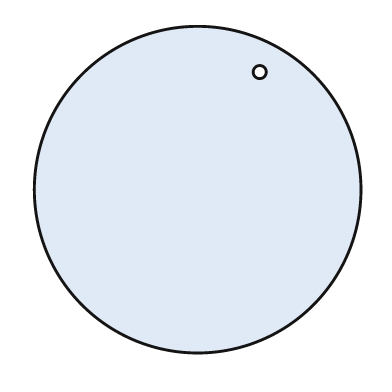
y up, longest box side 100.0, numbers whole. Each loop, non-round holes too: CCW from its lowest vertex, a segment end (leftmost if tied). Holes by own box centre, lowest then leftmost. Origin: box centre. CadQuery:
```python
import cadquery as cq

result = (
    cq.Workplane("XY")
    .moveTo(0.0, 0.0)
    .circle(50.0)
    .moveTo(19.0, 36.0)
    .circle(2.0)
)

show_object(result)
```